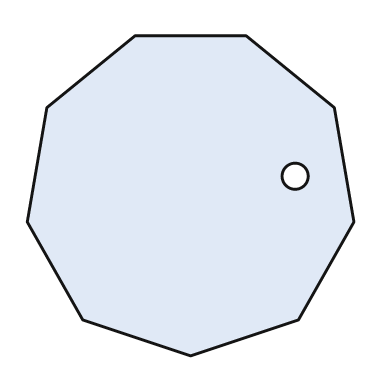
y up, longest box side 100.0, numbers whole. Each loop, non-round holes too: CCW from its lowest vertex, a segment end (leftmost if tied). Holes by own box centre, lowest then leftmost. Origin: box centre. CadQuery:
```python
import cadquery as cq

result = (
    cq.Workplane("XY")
    .moveTo(0.0, -49.0)
    .lineTo(33.0, -38.0)
    .lineTo(50.0, -8.0)
    .lineTo(44.0, 27.0)
    .lineTo(17.0, 49.0)
    .lineTo(-17.0, 49.0)
    .lineTo(-44.0, 27.0)
    .lineTo(-50.0, -8.0)
    .lineTo(-33.0, -38.0)
    .close()
    .moveTo(32.0, 6.0)
    .circle(4.0)
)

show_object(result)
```